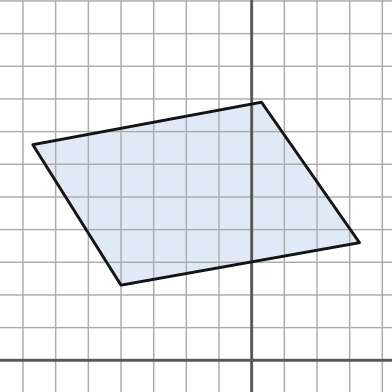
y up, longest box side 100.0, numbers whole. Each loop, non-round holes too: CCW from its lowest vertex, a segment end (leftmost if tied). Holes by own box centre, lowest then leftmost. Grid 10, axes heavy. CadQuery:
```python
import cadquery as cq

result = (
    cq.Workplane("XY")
    .moveTo(-40.0, 23.0)
    .lineTo(33.0, 36.0)
    .lineTo(3.0, 79.0)
    .lineTo(-67.0, 66.0)
    .close()
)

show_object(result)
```